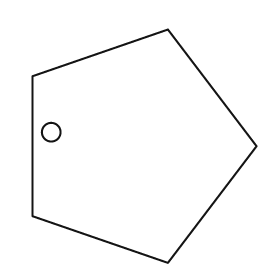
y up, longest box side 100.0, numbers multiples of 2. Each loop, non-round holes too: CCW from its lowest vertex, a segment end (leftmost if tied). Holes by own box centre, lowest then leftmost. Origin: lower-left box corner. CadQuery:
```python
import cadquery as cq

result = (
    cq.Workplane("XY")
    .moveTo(58.0, 0.0)
    .lineTo(96.0, 50.0)
    .lineTo(58.0, 100.0)
    .lineTo(0.0, 80.0)
    .lineTo(0.0, 20.0)
    .close()
    .moveTo(8.0, 56.0)
    .circle(4.0)
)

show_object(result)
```